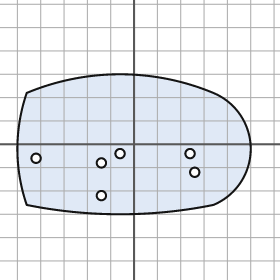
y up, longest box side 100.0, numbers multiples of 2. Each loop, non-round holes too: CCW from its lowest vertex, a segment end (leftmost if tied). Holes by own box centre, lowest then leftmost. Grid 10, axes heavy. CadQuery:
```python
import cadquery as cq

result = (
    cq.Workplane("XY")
    .moveTo(-46.0, -26.0)
    .threePointArc((-6.0, -30.0), (34.0, -26.0))
    .threePointArc((50.0, -2.0), (34.0, 22.0))
    .threePointArc((-6.0, 30.0), (-46.0, 22.0))
    .threePointArc((-50.0, -2.0), (-46.0, -26.0))
    .close()
    .moveTo(-14.0, -22.0)
    .circle(2.0)
    .moveTo(26.0, -12.0)
    .circle(2.0)
    .moveTo(-14.0, -8.0)
    .circle(2.0)
    .moveTo(-42.0, -6.0)
    .circle(2.0)
    .moveTo(-6.0, -4.0)
    .circle(2.0)
    .moveTo(24.0, -4.0)
    .circle(2.0)
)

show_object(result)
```